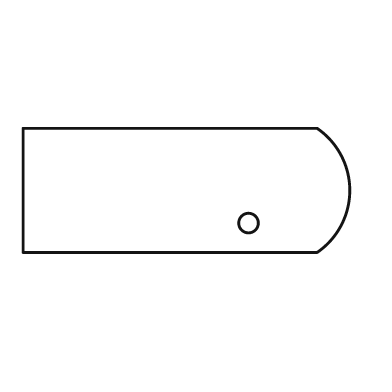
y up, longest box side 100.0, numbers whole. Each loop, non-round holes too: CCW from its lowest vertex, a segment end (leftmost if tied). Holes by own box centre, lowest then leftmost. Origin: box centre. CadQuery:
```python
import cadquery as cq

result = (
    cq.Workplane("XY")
    .moveTo(-50.0, -19.0)
    .lineTo(40.0, -19.0)
    .threePointArc((50.0, 0.0), (40.0, 19.0))
    .lineTo(-50.0, 19.0)
    .close()
    .moveTo(19.0, -10.0)
    .circle(3.0)
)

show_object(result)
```